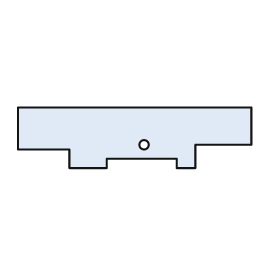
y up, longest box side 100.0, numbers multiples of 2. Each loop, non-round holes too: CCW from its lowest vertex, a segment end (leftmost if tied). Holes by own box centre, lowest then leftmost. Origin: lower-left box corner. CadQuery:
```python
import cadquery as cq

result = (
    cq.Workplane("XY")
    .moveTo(22.0, 0.0)
    .lineTo(38.0, 0.0)
    .lineTo(38.0, 4.0)
    .lineTo(68.0, 4.0)
    .lineTo(68.0, 0.0)
    .lineTo(76.0, 0.0)
    .lineTo(76.0, 10.0)
    .lineTo(100.0, 10.0)
    .lineTo(100.0, 26.0)
    .lineTo(0.0, 26.0)
    .lineTo(0.0, 8.0)
    .lineTo(22.0, 8.0)
    .close()
    .moveTo(54.0, 10.0)
    .circle(2.0)
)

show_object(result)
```